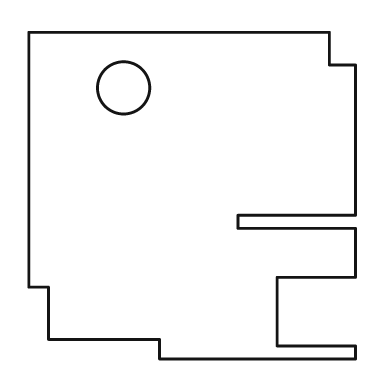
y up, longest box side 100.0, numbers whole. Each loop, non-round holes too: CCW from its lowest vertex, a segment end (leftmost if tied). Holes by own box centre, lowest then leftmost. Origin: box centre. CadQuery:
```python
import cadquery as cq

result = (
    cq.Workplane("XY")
    .moveTo(-10.0, -50.0)
    .lineTo(50.0, -50.0)
    .lineTo(50.0, -46.0)
    .lineTo(26.0, -46.0)
    .lineTo(26.0, -25.0)
    .lineTo(50.0, -25.0)
    .lineTo(50.0, -10.0)
    .lineTo(14.0, -10.0)
    .lineTo(14.0, -6.0)
    .lineTo(50.0, -6.0)
    .lineTo(50.0, 40.0)
    .lineTo(42.0, 40.0)
    .lineTo(42.0, 50.0)
    .lineTo(-50.0, 50.0)
    .lineTo(-50.0, -28.0)
    .lineTo(-44.0, -28.0)
    .lineTo(-44.0, -44.0)
    .lineTo(-10.0, -44.0)
    .close()
    .moveTo(-21.0, 33.0)
    .circle(8.0)
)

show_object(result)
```